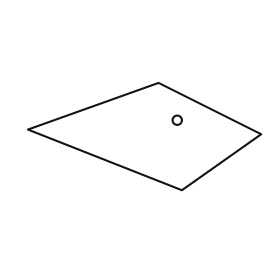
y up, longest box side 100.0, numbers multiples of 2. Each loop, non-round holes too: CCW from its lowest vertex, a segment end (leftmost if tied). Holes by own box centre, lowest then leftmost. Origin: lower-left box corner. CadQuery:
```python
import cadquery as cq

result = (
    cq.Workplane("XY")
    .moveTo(66.0, 0.0)
    .lineTo(100.0, 24.0)
    .lineTo(56.0, 46.0)
    .lineTo(0.0, 26.0)
    .close()
    .moveTo(64.0, 30.0)
    .circle(2.0)
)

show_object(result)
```